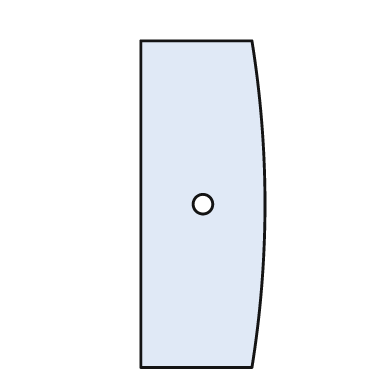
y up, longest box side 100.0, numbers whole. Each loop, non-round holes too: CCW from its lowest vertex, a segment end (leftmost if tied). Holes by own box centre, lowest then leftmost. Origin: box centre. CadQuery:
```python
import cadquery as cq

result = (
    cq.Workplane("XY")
    .moveTo(-19.0, -50.0)
    .lineTo(15.0, -50.0)
    .threePointArc((19.0, 0.0), (15.0, 50.0))
    .lineTo(-19.0, 50.0)
    .close()
    .moveTo(0.0, 0.0)
    .circle(3.0)
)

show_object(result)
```